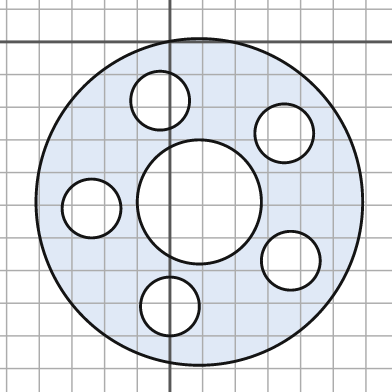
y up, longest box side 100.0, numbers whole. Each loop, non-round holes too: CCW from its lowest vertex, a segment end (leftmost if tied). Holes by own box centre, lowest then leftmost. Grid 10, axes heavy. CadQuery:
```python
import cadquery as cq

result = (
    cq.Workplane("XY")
    .moveTo(9.0, -49.0)
    .circle(50.0)
    .moveTo(0.0, -81.0)
    .circle(9.0)
    .moveTo(37.0, -67.0)
    .circle(9.0)
    .moveTo(-24.0, -51.0)
    .circle(9.0)
    .moveTo(9.0, -49.0)
    .circle(19.0)
    .moveTo(35.0, -28.0)
    .circle(9.0)
    .moveTo(-3.0, -18.0)
    .circle(9.0)
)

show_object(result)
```